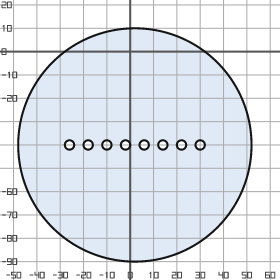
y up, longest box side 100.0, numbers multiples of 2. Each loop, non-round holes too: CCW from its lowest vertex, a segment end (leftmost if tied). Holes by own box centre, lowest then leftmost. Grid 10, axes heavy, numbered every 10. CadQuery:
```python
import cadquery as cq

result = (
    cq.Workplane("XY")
    .moveTo(2.0, -40.0)
    .circle(50.0)
    .moveTo(-26.0, -40.0)
    .circle(2.0)
    .moveTo(-18.0, -40.0)
    .circle(2.0)
    .moveTo(-10.0, -40.0)
    .circle(2.0)
    .moveTo(-2.0, -40.0)
    .circle(2.0)
    .moveTo(6.0, -40.0)
    .circle(2.0)
    .moveTo(14.0, -40.0)
    .circle(2.0)
    .moveTo(22.0, -40.0)
    .circle(2.0)
    .moveTo(30.0, -40.0)
    .circle(2.0)
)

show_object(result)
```